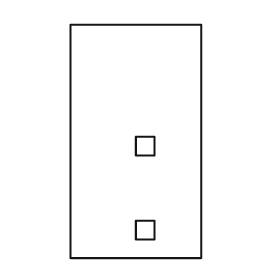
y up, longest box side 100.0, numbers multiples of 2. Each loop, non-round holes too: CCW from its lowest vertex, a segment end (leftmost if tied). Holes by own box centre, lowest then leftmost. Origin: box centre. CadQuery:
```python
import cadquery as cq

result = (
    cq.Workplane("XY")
    .moveTo(-28.0, -50.0)
    .lineTo(28.0, -50.0)
    .lineTo(28.0, 50.0)
    .lineTo(-28.0, 50.0)
    .close()
    .moveTo(0.0, -42.0)
    .lineTo(8.0, -42.0)
    .lineTo(8.0, -34.0)
    .lineTo(0.0, -34.0)
    .close()
    .moveTo(0.0, -6.0)
    .lineTo(8.0, -6.0)
    .lineTo(8.0, 2.0)
    .lineTo(0.0, 2.0)
    .close()
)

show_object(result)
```